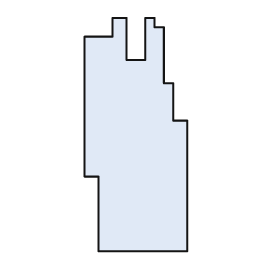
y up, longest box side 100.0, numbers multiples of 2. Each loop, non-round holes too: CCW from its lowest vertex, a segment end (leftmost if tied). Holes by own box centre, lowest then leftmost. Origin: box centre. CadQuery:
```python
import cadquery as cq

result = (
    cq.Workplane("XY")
    .moveTo(-16.0, -50.0)
    .lineTo(22.0, -50.0)
    .lineTo(22.0, 6.0)
    .lineTo(16.0, 6.0)
    .lineTo(16.0, 22.0)
    .lineTo(12.0, 22.0)
    .lineTo(12.0, 46.0)
    .lineTo(8.0, 46.0)
    .lineTo(8.0, 50.0)
    .lineTo(4.0, 50.0)
    .lineTo(4.0, 32.0)
    .lineTo(-4.0, 32.0)
    .lineTo(-4.0, 50.0)
    .lineTo(-10.0, 50.0)
    .lineTo(-10.0, 42.0)
    .lineTo(-22.0, 42.0)
    .lineTo(-22.0, -18.0)
    .lineTo(-16.0, -18.0)
    .close()
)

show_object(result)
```